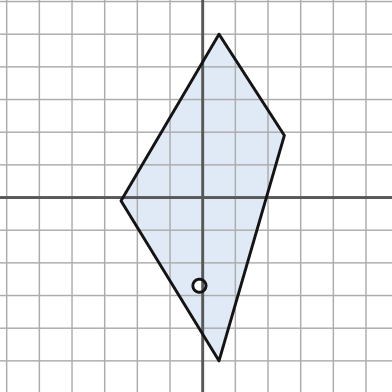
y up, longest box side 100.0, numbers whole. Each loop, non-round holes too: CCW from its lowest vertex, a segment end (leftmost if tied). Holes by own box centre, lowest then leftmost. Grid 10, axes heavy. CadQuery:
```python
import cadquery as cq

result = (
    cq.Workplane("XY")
    .moveTo(5.0, -50.0)
    .lineTo(25.0, 19.0)
    .lineTo(5.0, 50.0)
    .lineTo(-25.0, -1.0)
    .close()
    .moveTo(-1.0, -27.0)
    .circle(2.0)
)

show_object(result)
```